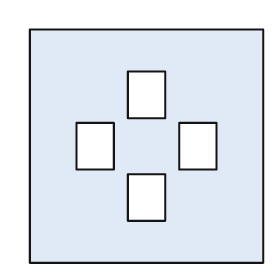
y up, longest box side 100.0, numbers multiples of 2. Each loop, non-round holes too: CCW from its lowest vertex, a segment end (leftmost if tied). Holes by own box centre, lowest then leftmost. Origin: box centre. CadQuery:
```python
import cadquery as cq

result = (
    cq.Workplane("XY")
    .moveTo(-50.0, -50.0)
    .lineTo(50.0, -50.0)
    .lineTo(50.0, 50.0)
    .lineTo(-50.0, 50.0)
    .close()
    .moveTo(-8.0, -32.0)
    .lineTo(8.0, -32.0)
    .lineTo(8.0, -12.0)
    .lineTo(-8.0, -12.0)
    .close()
    .moveTo(-30.0, -10.0)
    .lineTo(-14.0, -10.0)
    .lineTo(-14.0, 10.0)
    .lineTo(-30.0, 10.0)
    .close()
    .moveTo(14.0, -10.0)
    .lineTo(30.0, -10.0)
    .lineTo(30.0, 10.0)
    .lineTo(14.0, 10.0)
    .close()
    .moveTo(-8.0, 12.0)
    .lineTo(8.0, 12.0)
    .lineTo(8.0, 32.0)
    .lineTo(-8.0, 32.0)
    .close()
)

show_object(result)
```